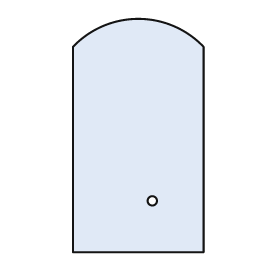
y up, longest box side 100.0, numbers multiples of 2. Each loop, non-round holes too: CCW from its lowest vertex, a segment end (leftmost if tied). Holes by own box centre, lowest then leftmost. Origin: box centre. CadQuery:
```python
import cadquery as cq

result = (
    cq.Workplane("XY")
    .moveTo(-28.0, -50.0)
    .lineTo(28.0, -50.0)
    .lineTo(28.0, 38.0)
    .threePointArc((0.0, 50.0), (-28.0, 38.0))
    .close()
    .moveTo(6.0, -28.0)
    .circle(2.0)
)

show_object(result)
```